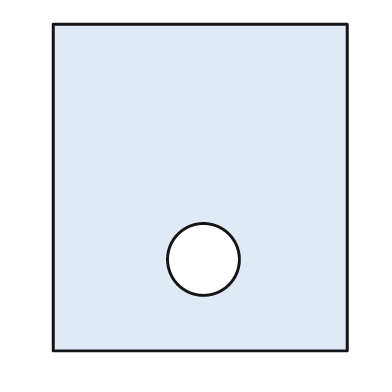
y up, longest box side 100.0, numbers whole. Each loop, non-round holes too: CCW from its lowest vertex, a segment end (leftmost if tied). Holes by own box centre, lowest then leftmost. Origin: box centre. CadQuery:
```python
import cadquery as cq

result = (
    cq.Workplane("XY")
    .moveTo(-45.0, -50.0)
    .lineTo(45.0, -50.0)
    .lineTo(45.0, 50.0)
    .lineTo(-45.0, 50.0)
    .close()
    .moveTo(1.0, -22.0)
    .circle(11.0)
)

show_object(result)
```